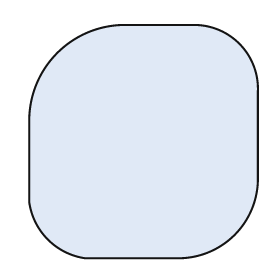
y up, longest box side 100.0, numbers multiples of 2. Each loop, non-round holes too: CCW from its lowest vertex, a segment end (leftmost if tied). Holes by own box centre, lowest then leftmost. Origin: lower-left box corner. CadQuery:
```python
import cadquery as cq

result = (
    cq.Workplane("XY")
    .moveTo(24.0, 0.0)
    .lineTo(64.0, 0.0)
    .threePointArc((88.0, 10.0), (98.0, 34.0))
    .lineTo(98.0, 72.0)
    .threePointArc((90.0, 92.0), (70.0, 100.0))
    .lineTo(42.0, 100.0)
    .threePointArc((12.0, 88.0), (0.0, 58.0))
    .lineTo(0.0, 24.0)
    .threePointArc((8.0, 8.0), (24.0, 0.0))
    .close()
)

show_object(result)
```